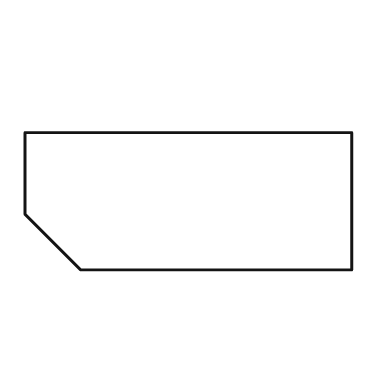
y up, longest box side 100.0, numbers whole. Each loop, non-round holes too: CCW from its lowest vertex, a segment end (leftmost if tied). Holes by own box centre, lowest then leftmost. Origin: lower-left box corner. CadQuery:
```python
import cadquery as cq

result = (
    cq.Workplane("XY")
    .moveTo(17.0, 0.0)
    .lineTo(100.0, 0.0)
    .lineTo(100.0, 42.0)
    .lineTo(0.0, 42.0)
    .lineTo(0.0, 17.0)
    .close()
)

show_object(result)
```